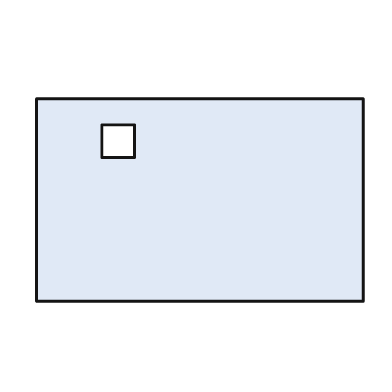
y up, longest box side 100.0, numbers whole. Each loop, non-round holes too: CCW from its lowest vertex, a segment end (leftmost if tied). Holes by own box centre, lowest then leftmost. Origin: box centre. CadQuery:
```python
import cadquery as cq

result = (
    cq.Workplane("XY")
    .moveTo(-50.0, -31.0)
    .lineTo(50.0, -31.0)
    .lineTo(50.0, 31.0)
    .lineTo(-50.0, 31.0)
    .close()
    .moveTo(-30.0, 13.0)
    .lineTo(-20.0, 13.0)
    .lineTo(-20.0, 23.0)
    .lineTo(-30.0, 23.0)
    .close()
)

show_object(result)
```